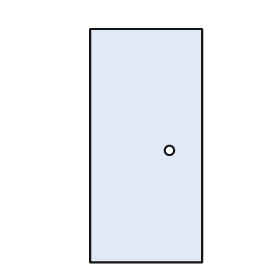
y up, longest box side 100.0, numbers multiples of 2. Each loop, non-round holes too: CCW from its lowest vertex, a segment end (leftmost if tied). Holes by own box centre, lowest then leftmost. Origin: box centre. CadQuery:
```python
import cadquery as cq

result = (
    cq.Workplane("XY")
    .moveTo(-24.0, -50.0)
    .lineTo(24.0, -50.0)
    .lineTo(24.0, 50.0)
    .lineTo(-24.0, 50.0)
    .close()
    .moveTo(10.0, -2.0)
    .circle(2.0)
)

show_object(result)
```